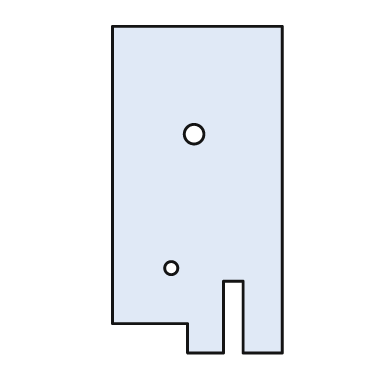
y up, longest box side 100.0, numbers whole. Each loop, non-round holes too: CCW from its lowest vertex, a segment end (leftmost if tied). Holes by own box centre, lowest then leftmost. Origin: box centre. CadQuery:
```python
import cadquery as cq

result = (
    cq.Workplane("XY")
    .moveTo(-3.0, -50.0)
    .lineTo(8.0, -50.0)
    .lineTo(8.0, -28.0)
    .lineTo(14.0, -28.0)
    .lineTo(14.0, -50.0)
    .lineTo(26.0, -50.0)
    .lineTo(26.0, 50.0)
    .lineTo(-26.0, 50.0)
    .lineTo(-26.0, -41.0)
    .lineTo(-3.0, -41.0)
    .close()
    .moveTo(-8.0, -24.0)
    .circle(2.0)
    .moveTo(-1.0, 17.0)
    .circle(3.0)
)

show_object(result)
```